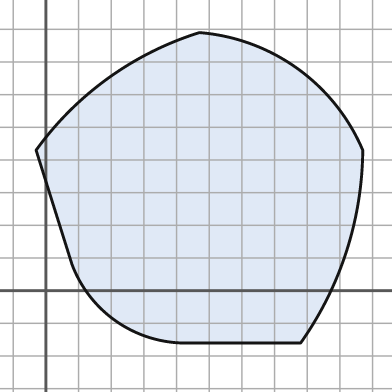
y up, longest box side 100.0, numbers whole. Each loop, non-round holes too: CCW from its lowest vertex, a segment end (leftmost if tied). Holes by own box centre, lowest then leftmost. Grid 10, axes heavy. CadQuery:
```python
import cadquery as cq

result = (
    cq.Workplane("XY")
    .moveTo(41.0, -16.0)
    .lineTo(78.0, -16.0)
    .threePointArc((92.0, 12.0), (97.0, 43.0))
    .threePointArc((77.0, 68.0), (47.0, 79.0))
    .threePointArc((19.0, 65.0), (-3.0, 43.0))
    .lineTo(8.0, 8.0)
    .threePointArc((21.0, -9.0), (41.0, -16.0))
    .close()
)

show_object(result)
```